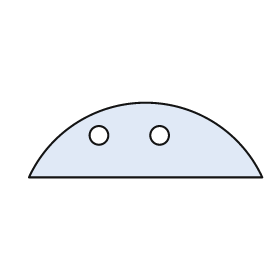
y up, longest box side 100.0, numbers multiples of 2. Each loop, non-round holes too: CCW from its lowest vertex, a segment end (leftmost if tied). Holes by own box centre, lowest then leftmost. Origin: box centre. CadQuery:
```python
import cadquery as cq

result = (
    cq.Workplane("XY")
    .moveTo(-50.0, -16.0)
    .lineTo(50.0, -16.0)
    .threePointArc((0.0, 16.0), (-50.0, -16.0))
    .close()
    .moveTo(-20.0, 2.0)
    .circle(4.0)
    .moveTo(6.0, 2.0)
    .circle(4.0)
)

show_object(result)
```